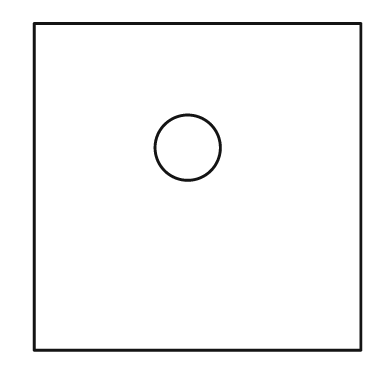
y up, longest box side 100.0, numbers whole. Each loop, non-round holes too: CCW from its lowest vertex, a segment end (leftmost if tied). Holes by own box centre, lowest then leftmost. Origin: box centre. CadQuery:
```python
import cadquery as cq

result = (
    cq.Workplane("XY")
    .moveTo(-50.0, -50.0)
    .lineTo(50.0, -50.0)
    .lineTo(50.0, 50.0)
    .lineTo(-50.0, 50.0)
    .close()
    .moveTo(-3.0, 12.0)
    .circle(10.0)
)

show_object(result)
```